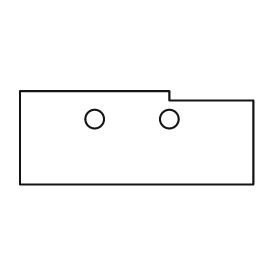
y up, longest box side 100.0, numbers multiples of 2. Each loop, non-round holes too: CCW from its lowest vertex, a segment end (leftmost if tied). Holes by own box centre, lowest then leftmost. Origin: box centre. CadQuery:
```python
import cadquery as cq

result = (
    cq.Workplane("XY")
    .moveTo(-50.0, -20.0)
    .lineTo(50.0, -20.0)
    .lineTo(50.0, 16.0)
    .lineTo(14.0, 16.0)
    .lineTo(14.0, 20.0)
    .lineTo(-50.0, 20.0)
    .close()
    .moveTo(-18.0, 8.0)
    .circle(4.0)
    .moveTo(14.0, 8.0)
    .circle(4.0)
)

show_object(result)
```